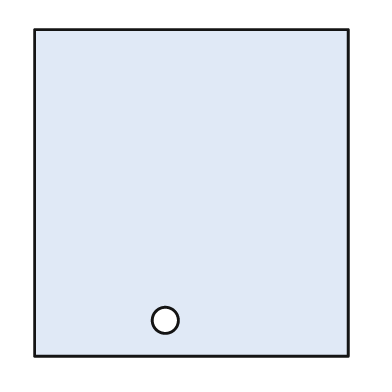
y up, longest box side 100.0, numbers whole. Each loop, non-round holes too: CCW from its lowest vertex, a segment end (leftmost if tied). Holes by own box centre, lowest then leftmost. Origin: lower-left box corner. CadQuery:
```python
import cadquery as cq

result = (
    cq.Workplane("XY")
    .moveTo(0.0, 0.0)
    .lineTo(96.0, 0.0)
    .lineTo(96.0, 100.0)
    .lineTo(0.0, 100.0)
    .close()
    .moveTo(40.0, 11.0)
    .circle(4.0)
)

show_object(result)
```